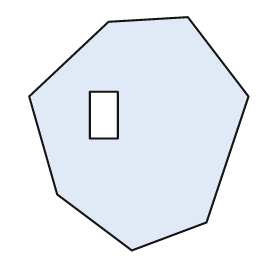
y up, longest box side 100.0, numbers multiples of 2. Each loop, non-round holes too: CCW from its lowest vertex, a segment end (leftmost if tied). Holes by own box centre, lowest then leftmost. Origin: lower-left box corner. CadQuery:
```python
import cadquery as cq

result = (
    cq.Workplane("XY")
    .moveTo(44.0, 0.0)
    .lineTo(76.0, 12.0)
    .lineTo(94.0, 66.0)
    .lineTo(68.0, 100.0)
    .lineTo(34.0, 98.0)
    .lineTo(0.0, 66.0)
    .lineTo(12.0, 24.0)
    .close()
    .moveTo(26.0, 48.0)
    .lineTo(38.0, 48.0)
    .lineTo(38.0, 68.0)
    .lineTo(26.0, 68.0)
    .close()
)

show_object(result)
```